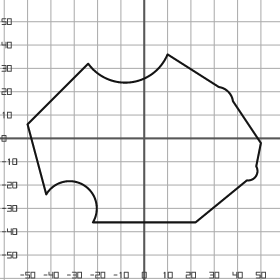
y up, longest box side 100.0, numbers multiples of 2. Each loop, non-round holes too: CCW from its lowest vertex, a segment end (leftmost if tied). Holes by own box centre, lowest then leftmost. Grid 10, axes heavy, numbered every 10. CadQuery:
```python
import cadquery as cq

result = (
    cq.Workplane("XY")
    .moveTo(-22.0, -36.0)
    .lineTo(22.0, -36.0)
    .lineTo(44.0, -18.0)
    .threePointArc((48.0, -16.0), (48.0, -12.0))
    .lineTo(50.0, -2.0)
    .lineTo(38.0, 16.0)
    .threePointArc((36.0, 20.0), (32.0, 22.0))
    .lineTo(10.0, 36.0)
    .threePointArc((-6.0, 24.0), (-24.0, 32.0))
    .lineTo(-50.0, 6.0)
    .lineTo(-42.0, -24.0)
    .threePointArc((-26.0, -20.0), (-22.0, -36.0))
    .close()
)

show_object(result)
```